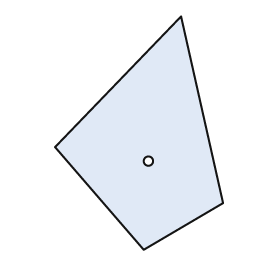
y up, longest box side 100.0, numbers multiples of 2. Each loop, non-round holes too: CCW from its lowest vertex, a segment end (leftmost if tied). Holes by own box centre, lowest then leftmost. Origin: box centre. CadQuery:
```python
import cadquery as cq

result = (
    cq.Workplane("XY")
    .moveTo(2.0, -50.0)
    .lineTo(36.0, -30.0)
    .lineTo(18.0, 50.0)
    .lineTo(-36.0, -6.0)
    .close()
    .moveTo(4.0, -12.0)
    .circle(2.0)
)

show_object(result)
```